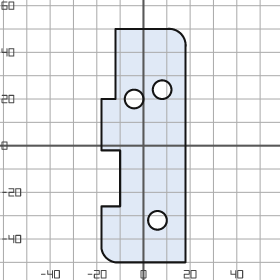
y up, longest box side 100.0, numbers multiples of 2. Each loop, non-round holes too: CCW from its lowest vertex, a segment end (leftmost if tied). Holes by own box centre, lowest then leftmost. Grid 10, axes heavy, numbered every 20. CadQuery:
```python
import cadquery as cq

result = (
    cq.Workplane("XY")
    .moveTo(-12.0, -50.0)
    .lineTo(18.0, -50.0)
    .lineTo(18.0, 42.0)
    .threePointArc((16.0, 48.0), (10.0, 50.0))
    .lineTo(-12.0, 50.0)
    .lineTo(-12.0, 20.0)
    .lineTo(-18.0, 20.0)
    .lineTo(-18.0, -2.0)
    .lineTo(-10.0, -2.0)
    .lineTo(-10.0, -26.0)
    .lineTo(-18.0, -26.0)
    .lineTo(-18.0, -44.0)
    .threePointArc((-16.0, -48.0), (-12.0, -50.0))
    .close()
    .moveTo(6.0, -32.0)
    .circle(4.0)
    .moveTo(-4.0, 20.0)
    .circle(4.0)
    .moveTo(8.0, 24.0)
    .circle(4.0)
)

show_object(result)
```